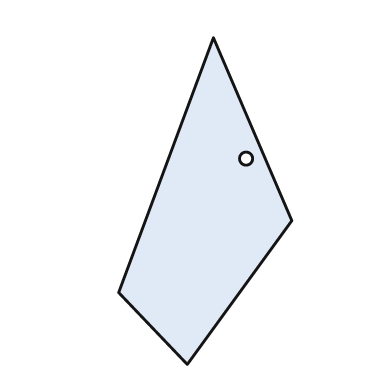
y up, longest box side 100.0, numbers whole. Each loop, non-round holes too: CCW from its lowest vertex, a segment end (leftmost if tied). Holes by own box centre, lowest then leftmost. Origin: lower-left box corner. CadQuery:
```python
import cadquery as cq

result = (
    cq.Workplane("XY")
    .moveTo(21.0, 0.0)
    .lineTo(53.0, 44.0)
    .lineTo(29.0, 100.0)
    .lineTo(0.0, 22.0)
    .close()
    .moveTo(39.0, 63.0)
    .circle(2.0)
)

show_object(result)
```